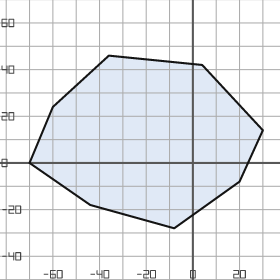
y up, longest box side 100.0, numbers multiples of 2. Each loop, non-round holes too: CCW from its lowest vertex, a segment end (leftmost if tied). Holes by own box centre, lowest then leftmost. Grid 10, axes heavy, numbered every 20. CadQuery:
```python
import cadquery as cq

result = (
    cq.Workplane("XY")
    .moveTo(-8.0, -28.0)
    .lineTo(20.0, -8.0)
    .lineTo(30.0, 14.0)
    .lineTo(4.0, 42.0)
    .lineTo(-36.0, 46.0)
    .lineTo(-60.0, 24.0)
    .lineTo(-70.0, 0.0)
    .lineTo(-44.0, -18.0)
    .close()
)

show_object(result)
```